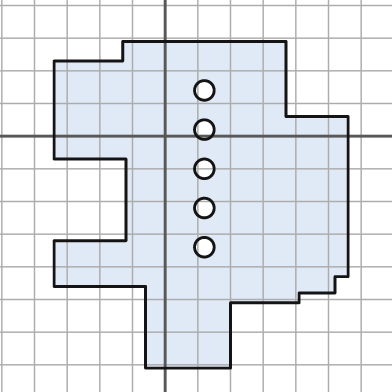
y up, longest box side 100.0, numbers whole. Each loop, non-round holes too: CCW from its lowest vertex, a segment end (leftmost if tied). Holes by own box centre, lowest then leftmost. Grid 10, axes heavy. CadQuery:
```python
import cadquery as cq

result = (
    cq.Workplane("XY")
    .moveTo(-6.0, -71.0)
    .lineTo(20.0, -71.0)
    .lineTo(20.0, -51.0)
    .lineTo(41.0, -51.0)
    .lineTo(41.0, -48.0)
    .lineTo(52.0, -48.0)
    .lineTo(52.0, -43.0)
    .lineTo(56.0, -43.0)
    .lineTo(56.0, 6.0)
    .lineTo(37.0, 6.0)
    .lineTo(37.0, 29.0)
    .lineTo(-13.0, 29.0)
    .lineTo(-13.0, 23.0)
    .lineTo(-34.0, 23.0)
    .lineTo(-34.0, -7.0)
    .lineTo(-12.0, -7.0)
    .lineTo(-12.0, -32.0)
    .lineTo(-34.0, -32.0)
    .lineTo(-34.0, -46.0)
    .lineTo(-6.0, -46.0)
    .close()
    .moveTo(12.0, -34.0)
    .circle(3.0)
    .moveTo(12.0, -22.0)
    .circle(3.0)
    .moveTo(12.0, -10.0)
    .circle(3.0)
    .moveTo(12.0, 2.0)
    .circle(3.0)
    .moveTo(12.0, 14.0)
    .circle(3.0)
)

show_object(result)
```